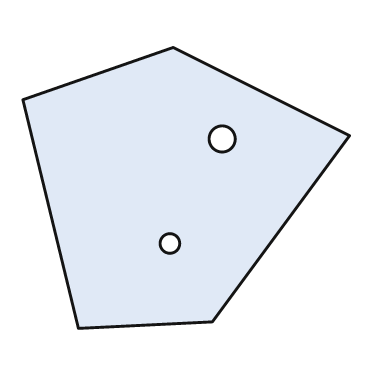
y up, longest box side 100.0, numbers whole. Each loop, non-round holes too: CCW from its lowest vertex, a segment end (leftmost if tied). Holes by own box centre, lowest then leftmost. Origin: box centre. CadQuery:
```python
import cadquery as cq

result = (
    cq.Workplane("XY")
    .moveTo(-33.0, -43.0)
    .lineTo(8.0, -41.0)
    .lineTo(50.0, 16.0)
    .lineTo(-4.0, 43.0)
    .lineTo(-50.0, 27.0)
    .close()
    .moveTo(-5.0, -17.0)
    .circle(3.0)
    .moveTo(11.0, 15.0)
    .circle(4.0)
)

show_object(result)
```